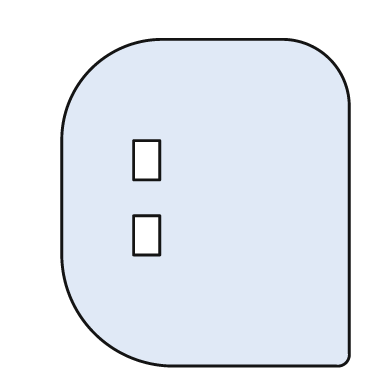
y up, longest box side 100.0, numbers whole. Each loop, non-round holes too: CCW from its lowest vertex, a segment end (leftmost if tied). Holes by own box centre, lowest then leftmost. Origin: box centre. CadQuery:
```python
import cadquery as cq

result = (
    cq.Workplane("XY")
    .moveTo(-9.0, -50.0)
    .lineTo(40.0, -50.0)
    .threePointArc((43.0, -49.0), (44.0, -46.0))
    .lineTo(44.0, 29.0)
    .threePointArc((38.0, 44.0), (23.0, 50.0))
    .lineTo(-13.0, 50.0)
    .threePointArc((-35.0, 41.0), (-44.0, 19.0))
    .lineTo(-44.0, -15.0)
    .threePointArc((-34.0, -40.0), (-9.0, -50.0))
    .close()
    .moveTo(-22.0, -16.0)
    .lineTo(-14.0, -16.0)
    .lineTo(-14.0, -4.0)
    .lineTo(-22.0, -4.0)
    .close()
    .moveTo(-22.0, 7.0)
    .lineTo(-14.0, 7.0)
    .lineTo(-14.0, 19.0)
    .lineTo(-22.0, 19.0)
    .close()
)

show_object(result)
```